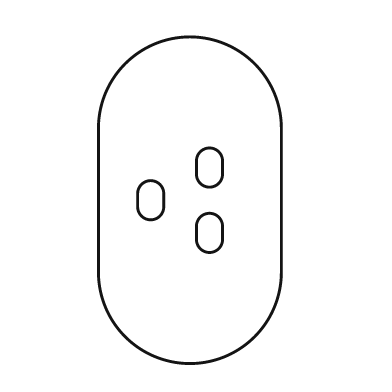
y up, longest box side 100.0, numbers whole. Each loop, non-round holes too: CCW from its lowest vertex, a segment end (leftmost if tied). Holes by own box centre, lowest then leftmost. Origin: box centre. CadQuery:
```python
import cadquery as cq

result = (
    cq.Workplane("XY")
    .moveTo(-28.0, -22.0)
    .threePointArc((0.0, -50.0), (28.0, -22.0))
    .lineTo(28.0, 22.0)
    .threePointArc((0.0, 50.0), (-28.0, 22.0))
    .close()
    .moveTo(2.0, -12.0)
    .threePointArc((6.0, -16.0), (10.0, -12.0))
    .lineTo(10.0, -8.0)
    .threePointArc((6.0, -4.0), (2.0, -8.0))
    .close()
    .moveTo(-16.0, -2.0)
    .threePointArc((-12.0, -6.0), (-8.0, -2.0))
    .lineTo(-8.0, 2.0)
    .threePointArc((-12.0, 6.0), (-16.0, 2.0))
    .close()
    .moveTo(2.0, 8.0)
    .threePointArc((6.0, 4.0), (10.0, 8.0))
    .lineTo(10.0, 12.0)
    .threePointArc((6.0, 16.0), (2.0, 12.0))
    .close()
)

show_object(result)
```